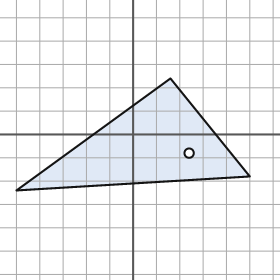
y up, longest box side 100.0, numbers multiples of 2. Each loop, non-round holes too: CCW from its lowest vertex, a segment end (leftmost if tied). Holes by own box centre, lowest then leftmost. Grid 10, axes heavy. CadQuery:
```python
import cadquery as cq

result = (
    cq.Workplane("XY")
    .moveTo(-50.0, -24.0)
    .lineTo(50.0, -18.0)
    .lineTo(16.0, 24.0)
    .close()
    .moveTo(24.0, -8.0)
    .circle(2.0)
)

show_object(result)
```